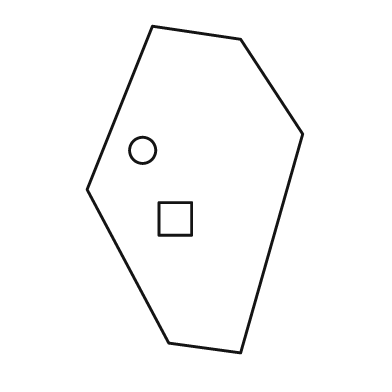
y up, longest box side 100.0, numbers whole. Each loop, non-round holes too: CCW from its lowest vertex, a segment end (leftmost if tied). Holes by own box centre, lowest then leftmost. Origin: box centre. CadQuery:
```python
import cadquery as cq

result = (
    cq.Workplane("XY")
    .moveTo(14.0, -50.0)
    .lineTo(33.0, 17.0)
    .lineTo(14.0, 46.0)
    .lineTo(-13.0, 50.0)
    .lineTo(-33.0, 0.0)
    .lineTo(-8.0, -47.0)
    .close()
    .moveTo(-11.0, -14.0)
    .lineTo(-1.0, -14.0)
    .lineTo(-1.0, -4.0)
    .lineTo(-11.0, -4.0)
    .close()
    .moveTo(-16.0, 12.0)
    .circle(4.0)
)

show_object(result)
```